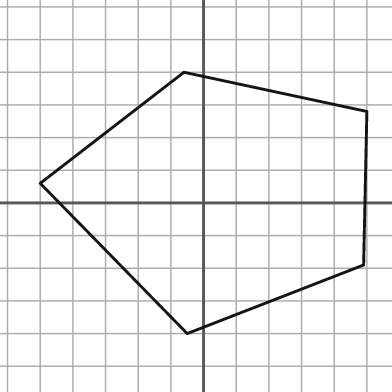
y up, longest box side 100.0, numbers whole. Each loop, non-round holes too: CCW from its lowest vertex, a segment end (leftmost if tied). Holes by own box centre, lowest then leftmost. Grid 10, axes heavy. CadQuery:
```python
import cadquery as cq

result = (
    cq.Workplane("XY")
    .moveTo(-5.0, -40.0)
    .lineTo(49.0, -19.0)
    .lineTo(50.0, 28.0)
    .lineTo(-6.0, 40.0)
    .lineTo(-50.0, 6.0)
    .close()
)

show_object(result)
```